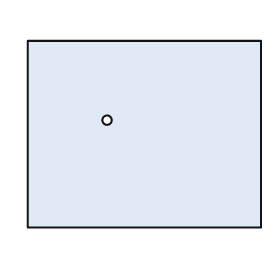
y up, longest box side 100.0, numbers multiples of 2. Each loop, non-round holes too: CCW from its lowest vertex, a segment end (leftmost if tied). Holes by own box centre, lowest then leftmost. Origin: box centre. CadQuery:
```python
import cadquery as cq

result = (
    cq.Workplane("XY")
    .moveTo(-50.0, -40.0)
    .lineTo(50.0, -40.0)
    .lineTo(50.0, 40.0)
    .lineTo(-50.0, 40.0)
    .close()
    .moveTo(-16.0, 6.0)
    .circle(2.0)
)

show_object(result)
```